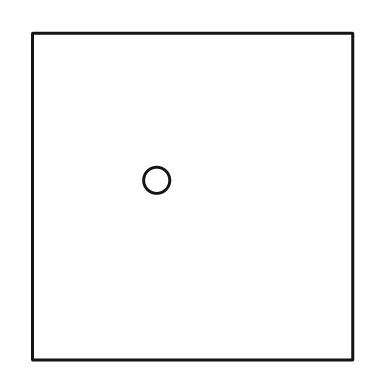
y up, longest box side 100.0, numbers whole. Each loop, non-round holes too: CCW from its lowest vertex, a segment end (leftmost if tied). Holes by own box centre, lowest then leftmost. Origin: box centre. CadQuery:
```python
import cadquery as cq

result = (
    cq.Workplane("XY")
    .moveTo(-49.0, -50.0)
    .lineTo(49.0, -50.0)
    .lineTo(49.0, 50.0)
    .lineTo(-49.0, 50.0)
    .close()
    .moveTo(-11.0, 5.0)
    .circle(4.0)
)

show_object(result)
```